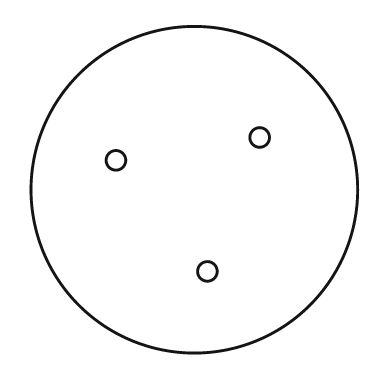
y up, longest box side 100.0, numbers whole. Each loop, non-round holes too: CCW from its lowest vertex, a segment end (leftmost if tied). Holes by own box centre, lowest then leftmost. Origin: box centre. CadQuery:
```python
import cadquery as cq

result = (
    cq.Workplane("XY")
    .moveTo(0.0, 0.0)
    .circle(50.0)
    .moveTo(4.0, -25.0)
    .circle(3.0)
    .moveTo(-24.0, 9.0)
    .circle(3.0)
    .moveTo(20.0, 16.0)
    .circle(3.0)
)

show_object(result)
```